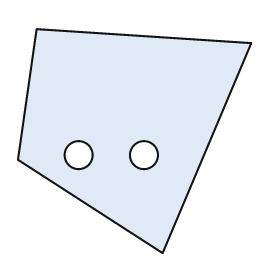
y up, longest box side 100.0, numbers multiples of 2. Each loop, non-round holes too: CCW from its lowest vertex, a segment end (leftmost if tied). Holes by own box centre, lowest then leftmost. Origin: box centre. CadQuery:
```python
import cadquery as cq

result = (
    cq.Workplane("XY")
    .moveTo(12.0, -48.0)
    .lineTo(50.0, 42.0)
    .lineTo(-42.0, 48.0)
    .lineTo(-50.0, -8.0)
    .close()
    .moveTo(-24.0, -6.0)
    .circle(6.0)
    .moveTo(4.0, -6.0)
    .circle(6.0)
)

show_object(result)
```